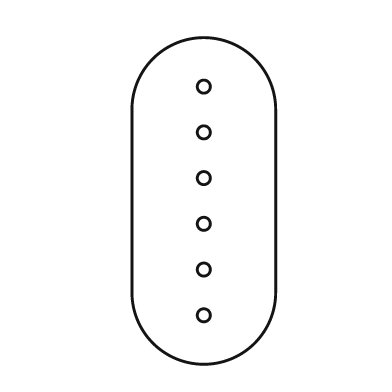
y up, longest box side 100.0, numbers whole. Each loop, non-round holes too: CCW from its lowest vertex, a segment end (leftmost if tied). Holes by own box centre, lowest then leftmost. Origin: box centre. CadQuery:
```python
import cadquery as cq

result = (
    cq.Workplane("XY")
    .moveTo(-22.0, -28.0)
    .threePointArc((0.0, -50.0), (22.0, -28.0))
    .lineTo(22.0, 28.0)
    .threePointArc((0.0, 50.0), (-22.0, 28.0))
    .close()
    .moveTo(0.0, -35.0)
    .circle(2.0)
    .moveTo(0.0, -21.0)
    .circle(2.0)
    .moveTo(0.0, -7.0)
    .circle(2.0)
    .moveTo(0.0, 7.0)
    .circle(2.0)
    .moveTo(0.0, 21.0)
    .circle(2.0)
    .moveTo(0.0, 35.0)
    .circle(2.0)
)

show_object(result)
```